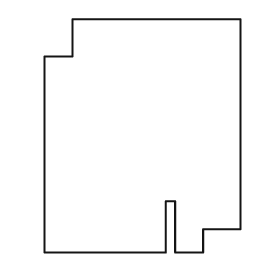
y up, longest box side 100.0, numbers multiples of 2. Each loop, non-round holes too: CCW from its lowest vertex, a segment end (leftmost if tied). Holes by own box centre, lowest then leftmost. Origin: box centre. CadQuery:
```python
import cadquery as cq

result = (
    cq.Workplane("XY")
    .moveTo(-42.0, -50.0)
    .lineTo(10.0, -50.0)
    .lineTo(10.0, -28.0)
    .lineTo(14.0, -28.0)
    .lineTo(14.0, -50.0)
    .lineTo(26.0, -50.0)
    .lineTo(26.0, -40.0)
    .lineTo(42.0, -40.0)
    .lineTo(42.0, 50.0)
    .lineTo(-30.0, 50.0)
    .lineTo(-30.0, 34.0)
    .lineTo(-42.0, 34.0)
    .close()
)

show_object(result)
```